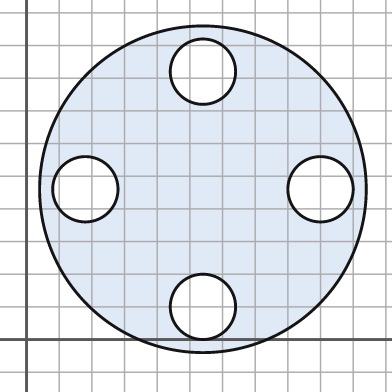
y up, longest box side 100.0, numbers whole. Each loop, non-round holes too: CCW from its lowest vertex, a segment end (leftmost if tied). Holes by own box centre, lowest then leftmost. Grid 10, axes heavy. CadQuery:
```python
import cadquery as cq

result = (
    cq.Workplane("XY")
    .moveTo(54.0, 46.0)
    .circle(50.0)
    .moveTo(54.0, 10.0)
    .circle(10.0)
    .moveTo(18.0, 46.0)
    .circle(10.0)
    .moveTo(90.0, 46.0)
    .circle(10.0)
    .moveTo(54.0, 82.0)
    .circle(10.0)
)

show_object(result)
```